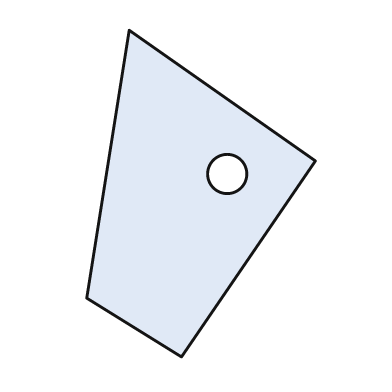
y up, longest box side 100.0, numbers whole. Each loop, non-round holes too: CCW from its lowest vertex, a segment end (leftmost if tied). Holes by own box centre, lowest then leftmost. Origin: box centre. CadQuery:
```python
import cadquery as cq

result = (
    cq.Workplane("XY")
    .moveTo(-6.0, -50.0)
    .lineTo(35.0, 10.0)
    .lineTo(-22.0, 50.0)
    .lineTo(-35.0, -32.0)
    .close()
    .moveTo(8.0, 6.0)
    .circle(6.0)
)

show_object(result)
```